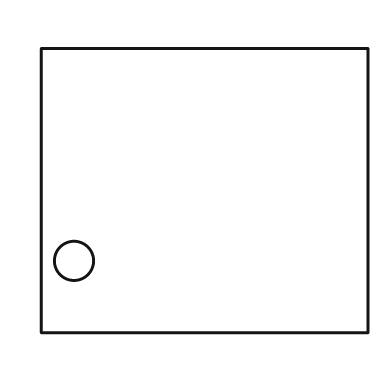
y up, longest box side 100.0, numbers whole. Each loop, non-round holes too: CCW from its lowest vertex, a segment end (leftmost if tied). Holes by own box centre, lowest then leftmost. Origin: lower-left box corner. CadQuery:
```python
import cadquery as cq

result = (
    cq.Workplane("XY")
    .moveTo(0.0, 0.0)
    .lineTo(100.0, 0.0)
    .lineTo(100.0, 87.0)
    .lineTo(0.0, 87.0)
    .close()
    .moveTo(10.0, 22.0)
    .circle(6.0)
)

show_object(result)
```